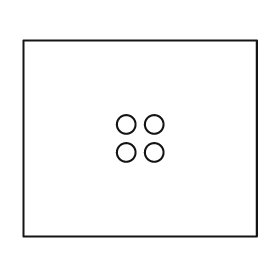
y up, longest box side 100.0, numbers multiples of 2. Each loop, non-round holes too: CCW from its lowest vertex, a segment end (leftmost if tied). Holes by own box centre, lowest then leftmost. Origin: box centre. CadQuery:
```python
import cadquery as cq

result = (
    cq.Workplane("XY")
    .moveTo(-50.0, -42.0)
    .lineTo(50.0, -42.0)
    .lineTo(50.0, 42.0)
    .lineTo(-50.0, 42.0)
    .close()
    .moveTo(-6.0, -6.0)
    .circle(4.0)
    .moveTo(6.0, -6.0)
    .circle(4.0)
    .moveTo(-6.0, 6.0)
    .circle(4.0)
    .moveTo(6.0, 6.0)
    .circle(4.0)
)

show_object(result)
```